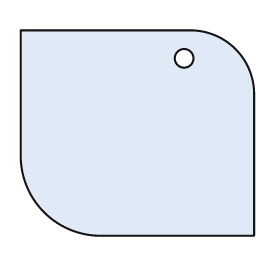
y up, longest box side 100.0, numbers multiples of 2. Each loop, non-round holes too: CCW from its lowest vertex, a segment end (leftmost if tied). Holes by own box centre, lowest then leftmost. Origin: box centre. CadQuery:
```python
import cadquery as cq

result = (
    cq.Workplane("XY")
    .moveTo(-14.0, -44.0)
    .lineTo(50.0, -44.0)
    .lineTo(50.0, 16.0)
    .threePointArc((42.0, 36.0), (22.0, 44.0))
    .lineTo(-50.0, 44.0)
    .lineTo(-50.0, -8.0)
    .threePointArc((-40.0, -34.0), (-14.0, -44.0))
    .close()
    .moveTo(20.0, 32.0)
    .circle(4.0)
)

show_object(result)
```